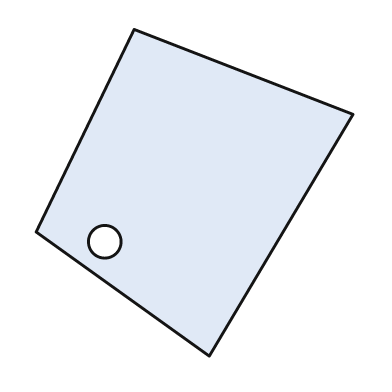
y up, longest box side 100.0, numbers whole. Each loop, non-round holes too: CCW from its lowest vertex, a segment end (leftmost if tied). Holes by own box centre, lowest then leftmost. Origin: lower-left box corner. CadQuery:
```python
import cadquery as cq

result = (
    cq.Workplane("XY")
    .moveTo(53.0, 0.0)
    .lineTo(97.0, 74.0)
    .lineTo(30.0, 100.0)
    .lineTo(0.0, 38.0)
    .close()
    .moveTo(21.0, 35.0)
    .circle(5.0)
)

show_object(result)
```